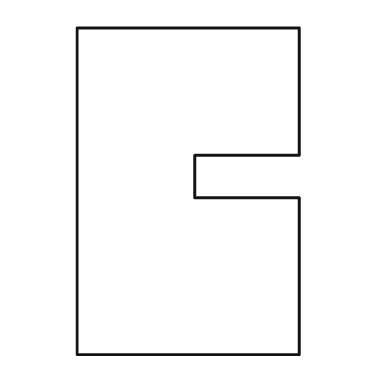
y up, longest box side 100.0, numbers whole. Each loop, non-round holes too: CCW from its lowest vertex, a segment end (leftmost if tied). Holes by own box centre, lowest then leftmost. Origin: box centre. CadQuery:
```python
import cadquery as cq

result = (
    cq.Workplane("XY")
    .moveTo(-34.0, -50.0)
    .lineTo(34.0, -50.0)
    .lineTo(34.0, -2.0)
    .lineTo(2.0, -2.0)
    .lineTo(2.0, 11.0)
    .lineTo(34.0, 11.0)
    .lineTo(34.0, 50.0)
    .lineTo(-34.0, 50.0)
    .close()
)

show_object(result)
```